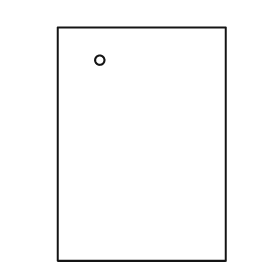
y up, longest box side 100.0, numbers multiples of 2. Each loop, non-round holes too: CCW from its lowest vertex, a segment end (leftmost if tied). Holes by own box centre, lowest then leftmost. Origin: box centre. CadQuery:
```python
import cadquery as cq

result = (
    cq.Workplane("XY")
    .moveTo(-36.0, -50.0)
    .lineTo(36.0, -50.0)
    .lineTo(36.0, 50.0)
    .lineTo(-36.0, 50.0)
    .close()
    .moveTo(-18.0, 36.0)
    .circle(2.0)
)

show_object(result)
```